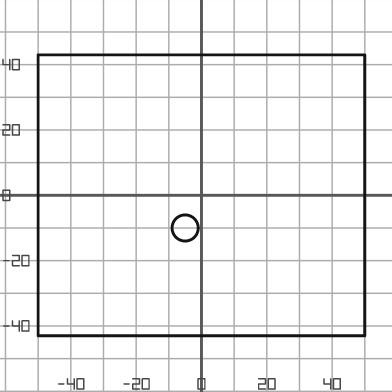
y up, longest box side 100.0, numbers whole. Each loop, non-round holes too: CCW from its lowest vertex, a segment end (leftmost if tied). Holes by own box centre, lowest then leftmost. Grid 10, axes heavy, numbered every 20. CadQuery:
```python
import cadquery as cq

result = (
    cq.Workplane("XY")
    .moveTo(-50.0, -43.0)
    .lineTo(50.0, -43.0)
    .lineTo(50.0, 43.0)
    .lineTo(-50.0, 43.0)
    .close()
    .moveTo(-5.0, -10.0)
    .circle(4.0)
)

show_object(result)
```